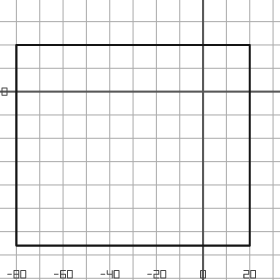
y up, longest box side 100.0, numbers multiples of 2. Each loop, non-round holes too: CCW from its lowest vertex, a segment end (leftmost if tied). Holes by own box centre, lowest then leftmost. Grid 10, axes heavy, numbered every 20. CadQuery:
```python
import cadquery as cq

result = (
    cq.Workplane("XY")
    .moveTo(-80.0, -66.0)
    .lineTo(20.0, -66.0)
    .lineTo(20.0, 20.0)
    .lineTo(-80.0, 20.0)
    .close()
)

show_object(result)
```